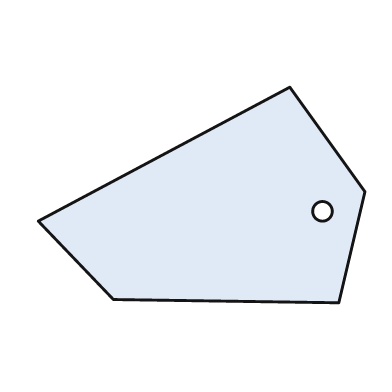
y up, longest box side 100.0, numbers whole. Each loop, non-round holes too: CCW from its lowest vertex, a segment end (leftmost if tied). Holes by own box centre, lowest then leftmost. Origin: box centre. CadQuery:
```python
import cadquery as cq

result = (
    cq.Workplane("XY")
    .moveTo(42.0, -33.0)
    .lineTo(50.0, 1.0)
    .lineTo(27.0, 33.0)
    .lineTo(-50.0, -8.0)
    .lineTo(-27.0, -32.0)
    .close()
    .moveTo(37.0, -5.0)
    .circle(3.0)
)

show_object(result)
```